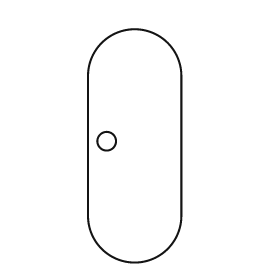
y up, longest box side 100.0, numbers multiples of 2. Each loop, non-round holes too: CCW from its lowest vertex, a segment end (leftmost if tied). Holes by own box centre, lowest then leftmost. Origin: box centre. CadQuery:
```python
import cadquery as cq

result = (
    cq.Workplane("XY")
    .moveTo(-20.0, -30.0)
    .threePointArc((0.0, -50.0), (20.0, -30.0))
    .lineTo(20.0, 30.0)
    .threePointArc((0.0, 50.0), (-20.0, 30.0))
    .close()
    .moveTo(-12.0, 2.0)
    .circle(4.0)
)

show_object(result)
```